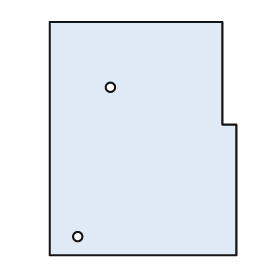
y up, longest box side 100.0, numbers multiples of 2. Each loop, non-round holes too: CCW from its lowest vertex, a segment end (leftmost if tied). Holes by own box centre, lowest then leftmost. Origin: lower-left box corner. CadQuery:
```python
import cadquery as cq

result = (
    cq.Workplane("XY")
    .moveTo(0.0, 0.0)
    .lineTo(80.0, 0.0)
    .lineTo(80.0, 56.0)
    .lineTo(74.0, 56.0)
    .lineTo(74.0, 100.0)
    .lineTo(0.0, 100.0)
    .close()
    .moveTo(12.0, 8.0)
    .circle(2.0)
    .moveTo(26.0, 72.0)
    .circle(2.0)
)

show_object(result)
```